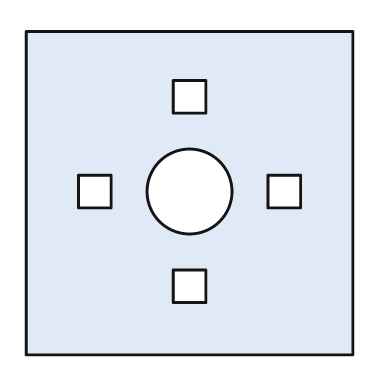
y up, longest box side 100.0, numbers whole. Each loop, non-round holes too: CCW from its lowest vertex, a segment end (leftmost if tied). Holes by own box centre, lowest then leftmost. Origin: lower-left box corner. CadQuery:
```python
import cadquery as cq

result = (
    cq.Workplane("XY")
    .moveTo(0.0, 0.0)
    .lineTo(100.0, 0.0)
    .lineTo(100.0, 99.0)
    .lineTo(0.0, 99.0)
    .close()
    .moveTo(45.0, 16.0)
    .lineTo(55.0, 16.0)
    .lineTo(55.0, 26.0)
    .lineTo(45.0, 26.0)
    .close()
    .moveTo(16.0, 45.0)
    .lineTo(26.0, 45.0)
    .lineTo(26.0, 55.0)
    .lineTo(16.0, 55.0)
    .close()
    .moveTo(50.0, 50.0)
    .circle(13.0)
    .moveTo(74.0, 45.0)
    .lineTo(84.0, 45.0)
    .lineTo(84.0, 55.0)
    .lineTo(74.0, 55.0)
    .close()
    .moveTo(45.0, 74.0)
    .lineTo(55.0, 74.0)
    .lineTo(55.0, 84.0)
    .lineTo(45.0, 84.0)
    .close()
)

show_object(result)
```